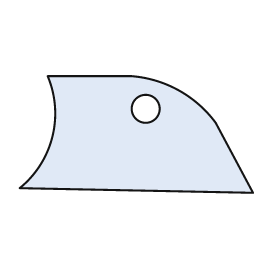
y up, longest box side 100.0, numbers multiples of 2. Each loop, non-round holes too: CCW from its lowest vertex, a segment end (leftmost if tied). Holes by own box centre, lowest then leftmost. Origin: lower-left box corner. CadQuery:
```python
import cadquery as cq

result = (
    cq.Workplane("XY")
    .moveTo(100.0, 0.0)
    .lineTo(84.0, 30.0)
    .threePointArc((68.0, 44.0), (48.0, 50.0))
    .lineTo(12.0, 50.0)
    .threePointArc((14.0, 24.0), (0.0, 2.0))
    .close()
    .moveTo(54.0, 36.0)
    .circle(6.0)
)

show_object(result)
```